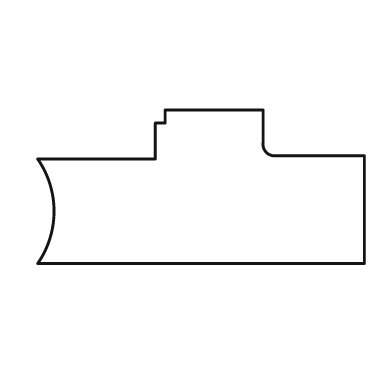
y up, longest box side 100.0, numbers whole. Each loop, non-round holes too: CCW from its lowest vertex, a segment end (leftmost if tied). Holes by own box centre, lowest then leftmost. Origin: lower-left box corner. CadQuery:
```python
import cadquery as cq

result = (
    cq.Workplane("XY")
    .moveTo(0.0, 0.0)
    .lineTo(100.0, 0.0)
    .lineTo(100.0, 33.0)
    .lineTo(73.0, 33.0)
    .threePointArc((70.0, 34.0), (69.0, 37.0))
    .lineTo(69.0, 47.0)
    .lineTo(39.0, 47.0)
    .lineTo(39.0, 43.0)
    .lineTo(36.0, 43.0)
    .lineTo(36.0, 32.0)
    .lineTo(0.0, 32.0)
    .threePointArc((5.0, 16.0), (0.0, 0.0))
    .close()
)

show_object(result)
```